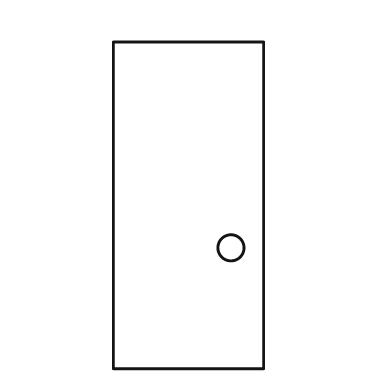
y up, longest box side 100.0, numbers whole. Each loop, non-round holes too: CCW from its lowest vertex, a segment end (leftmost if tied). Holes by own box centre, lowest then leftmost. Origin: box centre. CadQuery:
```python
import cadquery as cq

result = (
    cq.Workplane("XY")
    .moveTo(-23.0, -50.0)
    .lineTo(23.0, -50.0)
    .lineTo(23.0, 50.0)
    .lineTo(-23.0, 50.0)
    .close()
    .moveTo(13.0, -13.0)
    .circle(4.0)
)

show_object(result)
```